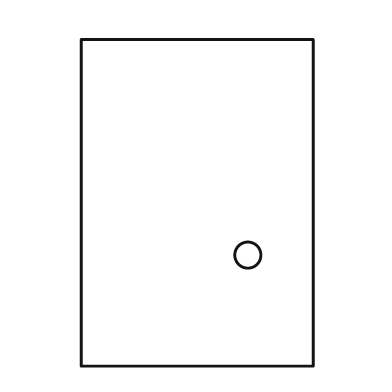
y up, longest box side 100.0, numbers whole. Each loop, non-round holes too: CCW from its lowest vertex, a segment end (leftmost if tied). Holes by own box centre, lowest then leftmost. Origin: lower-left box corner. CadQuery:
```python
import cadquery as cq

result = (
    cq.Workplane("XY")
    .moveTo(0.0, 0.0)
    .lineTo(71.0, 0.0)
    .lineTo(71.0, 100.0)
    .lineTo(0.0, 100.0)
    .close()
    .moveTo(51.0, 34.0)
    .circle(4.0)
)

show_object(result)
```